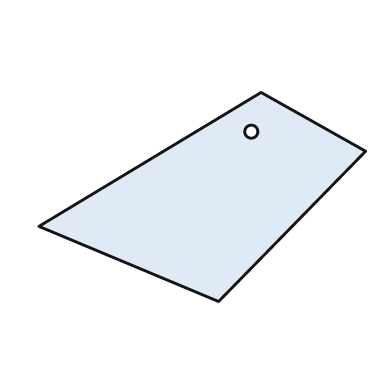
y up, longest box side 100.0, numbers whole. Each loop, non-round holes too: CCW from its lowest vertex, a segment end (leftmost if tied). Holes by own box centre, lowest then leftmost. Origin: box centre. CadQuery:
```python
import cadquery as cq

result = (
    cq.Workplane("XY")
    .moveTo(5.0, -32.0)
    .lineTo(50.0, 14.0)
    .lineTo(18.0, 32.0)
    .lineTo(-50.0, -9.0)
    .close()
    .moveTo(15.0, 20.0)
    .circle(2.0)
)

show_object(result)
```